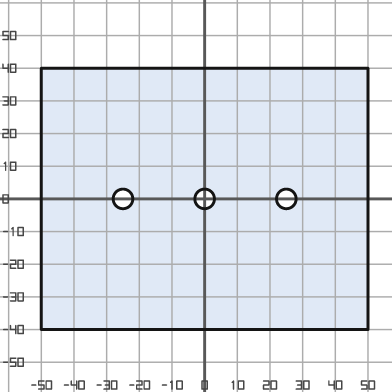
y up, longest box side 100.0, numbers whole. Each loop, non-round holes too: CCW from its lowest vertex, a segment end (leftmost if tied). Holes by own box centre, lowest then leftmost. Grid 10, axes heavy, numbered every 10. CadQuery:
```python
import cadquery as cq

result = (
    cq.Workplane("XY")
    .moveTo(-50.0, -40.0)
    .lineTo(50.0, -40.0)
    .lineTo(50.0, 40.0)
    .lineTo(-50.0, 40.0)
    .close()
    .moveTo(-25.0, 0.0)
    .circle(3.0)
    .moveTo(0.0, 0.0)
    .circle(3.0)
    .moveTo(25.0, 0.0)
    .circle(3.0)
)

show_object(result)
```